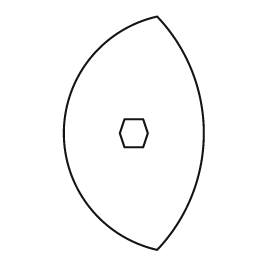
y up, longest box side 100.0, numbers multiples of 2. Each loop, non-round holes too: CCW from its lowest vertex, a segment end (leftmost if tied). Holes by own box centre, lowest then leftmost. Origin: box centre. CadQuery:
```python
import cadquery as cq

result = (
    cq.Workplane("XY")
    .moveTo(10.0, -50.0)
    .threePointArc((30.0, 0.0), (10.0, 50.0))
    .threePointArc((-30.0, 0.0), (10.0, -50.0))
    .close()
    .moveTo(-4.0, -6.0)
    .lineTo(4.0, -6.0)
    .lineTo(6.0, 0.0)
    .lineTo(4.0, 6.0)
    .lineTo(-4.0, 6.0)
    .lineTo(-6.0, 0.0)
    .close()
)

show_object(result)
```